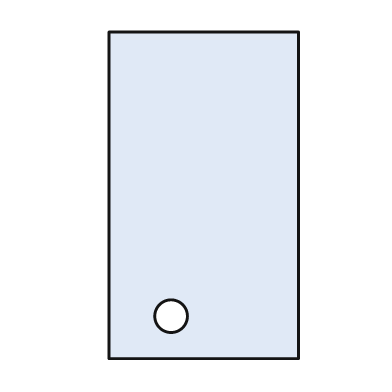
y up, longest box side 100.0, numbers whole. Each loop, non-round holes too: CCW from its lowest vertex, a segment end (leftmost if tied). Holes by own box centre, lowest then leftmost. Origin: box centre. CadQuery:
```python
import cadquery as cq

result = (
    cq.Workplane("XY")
    .moveTo(-29.0, -50.0)
    .lineTo(29.0, -50.0)
    .lineTo(29.0, 50.0)
    .lineTo(-29.0, 50.0)
    .close()
    .moveTo(-10.0, -37.0)
    .circle(5.0)
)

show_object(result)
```